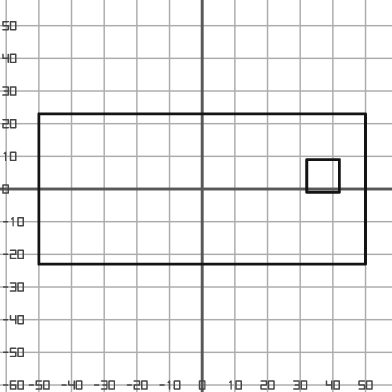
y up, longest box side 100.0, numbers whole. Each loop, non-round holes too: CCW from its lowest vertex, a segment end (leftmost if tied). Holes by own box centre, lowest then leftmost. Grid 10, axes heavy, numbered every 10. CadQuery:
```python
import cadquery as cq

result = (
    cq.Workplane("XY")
    .moveTo(-50.0, -23.0)
    .lineTo(50.0, -23.0)
    .lineTo(50.0, 23.0)
    .lineTo(-50.0, 23.0)
    .close()
    .moveTo(32.0, -1.0)
    .lineTo(42.0, -1.0)
    .lineTo(42.0, 9.0)
    .lineTo(32.0, 9.0)
    .close()
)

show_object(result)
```